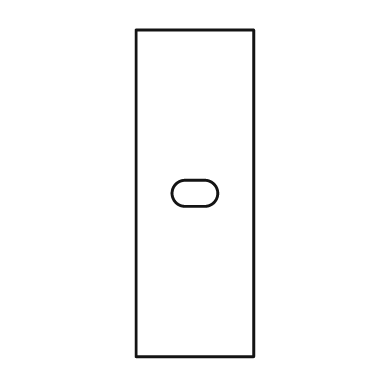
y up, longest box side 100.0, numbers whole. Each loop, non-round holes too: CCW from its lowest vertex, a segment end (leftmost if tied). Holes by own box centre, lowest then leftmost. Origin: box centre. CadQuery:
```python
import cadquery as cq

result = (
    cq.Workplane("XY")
    .moveTo(-18.0, -50.0)
    .lineTo(18.0, -50.0)
    .lineTo(18.0, 50.0)
    .lineTo(-18.0, 50.0)
    .close()
    .moveTo(-3.0, -4.0)
    .lineTo(3.0, -4.0)
    .threePointArc((7.0, 0.0), (3.0, 4.0))
    .lineTo(-3.0, 4.0)
    .threePointArc((-7.0, 0.0), (-3.0, -4.0))
    .close()
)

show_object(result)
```